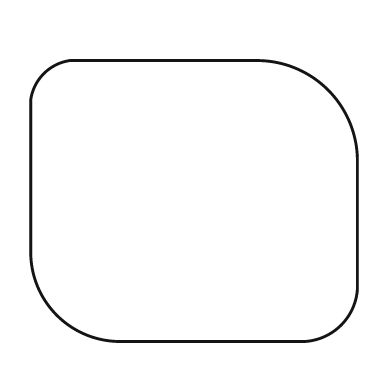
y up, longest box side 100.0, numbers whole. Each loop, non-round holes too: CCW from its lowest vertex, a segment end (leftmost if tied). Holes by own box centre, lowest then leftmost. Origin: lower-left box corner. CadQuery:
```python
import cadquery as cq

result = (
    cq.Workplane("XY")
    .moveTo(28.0, 0.0)
    .lineTo(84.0, 0.0)
    .threePointArc((95.0, 5.0), (100.0, 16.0))
    .lineTo(100.0, 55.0)
    .threePointArc((91.0, 77.0), (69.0, 86.0))
    .lineTo(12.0, 86.0)
    .threePointArc((4.0, 82.0), (0.0, 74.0))
    .lineTo(0.0, 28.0)
    .threePointArc((8.0, 8.0), (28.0, 0.0))
    .close()
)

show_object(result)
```